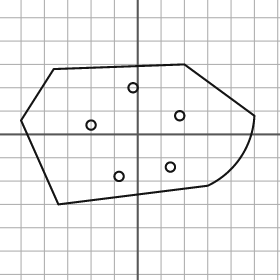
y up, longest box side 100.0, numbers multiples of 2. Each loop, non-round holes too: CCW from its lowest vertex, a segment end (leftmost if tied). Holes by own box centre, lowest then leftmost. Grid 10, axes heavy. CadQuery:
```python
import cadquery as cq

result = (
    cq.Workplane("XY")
    .moveTo(-34.0, -30.0)
    .lineTo(30.0, -22.0)
    .threePointArc((44.0, -10.0), (50.0, 8.0))
    .lineTo(20.0, 30.0)
    .lineTo(-36.0, 28.0)
    .lineTo(-50.0, 6.0)
    .close()
    .moveTo(-8.0, -18.0)
    .circle(2.0)
    .moveTo(14.0, -14.0)
    .circle(2.0)
    .moveTo(-20.0, 4.0)
    .circle(2.0)
    .moveTo(18.0, 8.0)
    .circle(2.0)
    .moveTo(-2.0, 20.0)
    .circle(2.0)
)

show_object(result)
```